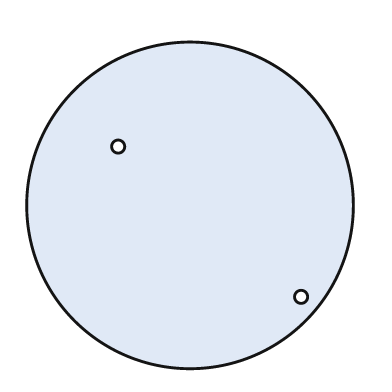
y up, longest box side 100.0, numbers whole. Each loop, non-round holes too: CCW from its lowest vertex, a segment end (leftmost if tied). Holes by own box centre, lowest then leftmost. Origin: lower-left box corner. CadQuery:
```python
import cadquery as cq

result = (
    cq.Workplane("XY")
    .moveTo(50.0, 50.0)
    .circle(50.0)
    .moveTo(84.0, 22.0)
    .circle(2.0)
    .moveTo(28.0, 68.0)
    .circle(2.0)
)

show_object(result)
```